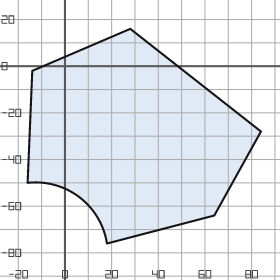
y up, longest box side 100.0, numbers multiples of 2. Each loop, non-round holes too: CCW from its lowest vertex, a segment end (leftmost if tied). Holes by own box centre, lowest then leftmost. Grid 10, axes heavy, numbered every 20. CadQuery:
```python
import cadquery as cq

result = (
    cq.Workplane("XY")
    .moveTo(18.0, -76.0)
    .lineTo(64.0, -64.0)
    .lineTo(84.0, -28.0)
    .lineTo(28.0, 16.0)
    .lineTo(-14.0, -2.0)
    .lineTo(-16.0, -50.0)
    .threePointArc((6.0, -56.0), (18.0, -76.0))
    .close()
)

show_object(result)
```